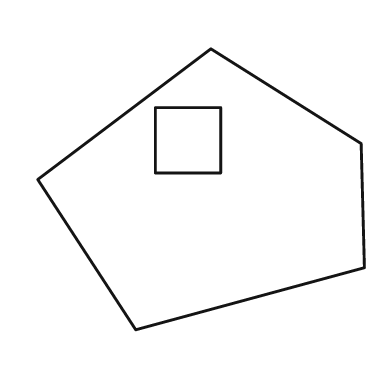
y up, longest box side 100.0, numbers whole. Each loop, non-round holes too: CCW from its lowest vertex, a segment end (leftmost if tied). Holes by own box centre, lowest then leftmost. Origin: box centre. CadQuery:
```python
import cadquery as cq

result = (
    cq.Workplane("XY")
    .moveTo(-20.0, -43.0)
    .lineTo(50.0, -24.0)
    .lineTo(49.0, 14.0)
    .lineTo(3.0, 43.0)
    .lineTo(-50.0, 3.0)
    .close()
    .moveTo(-14.0, 5.0)
    .lineTo(6.0, 5.0)
    .lineTo(6.0, 25.0)
    .lineTo(-14.0, 25.0)
    .close()
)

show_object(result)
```